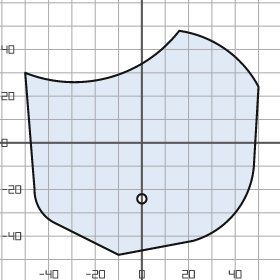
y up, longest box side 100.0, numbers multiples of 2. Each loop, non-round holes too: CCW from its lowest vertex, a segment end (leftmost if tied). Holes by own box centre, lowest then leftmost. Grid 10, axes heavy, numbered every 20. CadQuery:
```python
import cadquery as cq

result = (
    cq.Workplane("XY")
    .moveTo(-10.0, -48.0)
    .lineTo(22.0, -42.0)
    .threePointArc((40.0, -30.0), (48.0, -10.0))
    .lineTo(50.0, 24.0)
    .threePointArc((36.0, 40.0), (16.0, 48.0))
    .threePointArc((-14.0, 28.0), (-50.0, 30.0))
    .lineTo(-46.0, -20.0)
    .threePointArc((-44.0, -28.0), (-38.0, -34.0))
    .close()
    .moveTo(0.0, -24.0)
    .circle(2.0)
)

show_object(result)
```